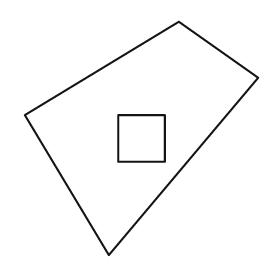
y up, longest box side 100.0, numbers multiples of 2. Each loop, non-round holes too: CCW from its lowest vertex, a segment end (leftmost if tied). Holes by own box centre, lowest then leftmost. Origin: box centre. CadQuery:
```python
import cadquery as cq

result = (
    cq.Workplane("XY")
    .moveTo(-14.0, -50.0)
    .lineTo(50.0, 26.0)
    .lineTo(16.0, 50.0)
    .lineTo(-50.0, 10.0)
    .close()
    .moveTo(-10.0, -10.0)
    .lineTo(10.0, -10.0)
    .lineTo(10.0, 10.0)
    .lineTo(-10.0, 10.0)
    .close()
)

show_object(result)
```